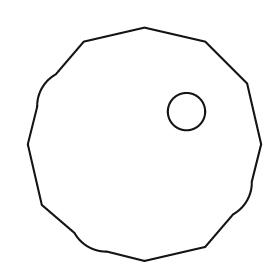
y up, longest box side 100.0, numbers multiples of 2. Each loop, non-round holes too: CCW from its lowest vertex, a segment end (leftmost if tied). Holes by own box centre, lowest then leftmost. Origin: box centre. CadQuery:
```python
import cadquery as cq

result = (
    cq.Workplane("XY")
    .moveTo(0.0, -50.0)
    .lineTo(26.0, -44.0)
    .lineTo(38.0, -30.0)
    .threePointArc((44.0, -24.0), (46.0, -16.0))
    .lineTo(50.0, 0.0)
    .lineTo(44.0, 26.0)
    .lineTo(26.0, 44.0)
    .lineTo(0.0, 50.0)
    .lineTo(-26.0, 44.0)
    .lineTo(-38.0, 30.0)
    .threePointArc((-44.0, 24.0), (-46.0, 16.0))
    .lineTo(-50.0, 0.0)
    .lineTo(-44.0, -26.0)
    .lineTo(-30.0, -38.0)
    .threePointArc((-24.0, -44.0), (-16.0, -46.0))
    .close()
    .moveTo(18.0, 14.0)
    .circle(8.0)
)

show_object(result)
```